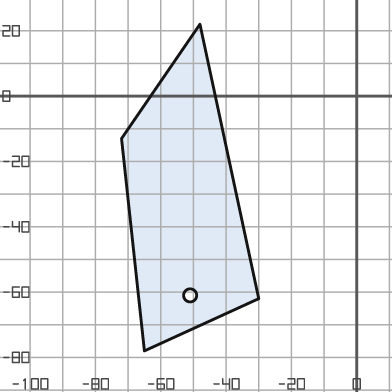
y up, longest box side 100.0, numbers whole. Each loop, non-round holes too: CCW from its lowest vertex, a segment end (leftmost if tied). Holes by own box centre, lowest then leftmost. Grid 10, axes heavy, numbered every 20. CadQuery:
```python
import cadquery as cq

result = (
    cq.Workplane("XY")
    .moveTo(-65.0, -78.0)
    .lineTo(-30.0, -62.0)
    .lineTo(-48.0, 22.0)
    .lineTo(-72.0, -13.0)
    .close()
    .moveTo(-51.0, -61.0)
    .circle(2.0)
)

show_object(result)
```